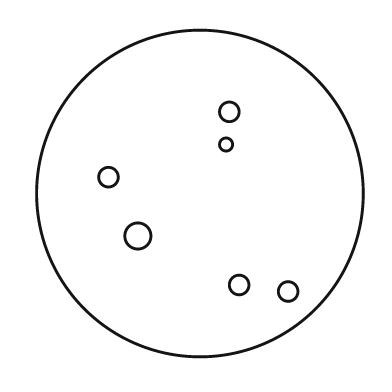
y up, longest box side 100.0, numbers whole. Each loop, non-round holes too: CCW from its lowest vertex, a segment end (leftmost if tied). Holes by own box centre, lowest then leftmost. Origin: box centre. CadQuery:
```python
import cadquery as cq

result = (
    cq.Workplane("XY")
    .moveTo(0.0, 0.0)
    .circle(50.0)
    .moveTo(27.0, -30.0)
    .circle(3.0)
    .moveTo(12.0, -28.0)
    .circle(3.0)
    .moveTo(-19.0, -13.0)
    .circle(4.0)
    .moveTo(-28.0, 5.0)
    .circle(3.0)
    .moveTo(8.0, 15.0)
    .circle(2.0)
    .moveTo(9.0, 25.0)
    .circle(3.0)
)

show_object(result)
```